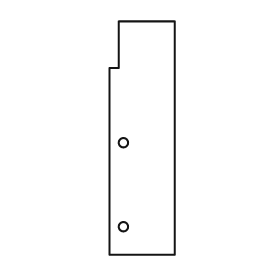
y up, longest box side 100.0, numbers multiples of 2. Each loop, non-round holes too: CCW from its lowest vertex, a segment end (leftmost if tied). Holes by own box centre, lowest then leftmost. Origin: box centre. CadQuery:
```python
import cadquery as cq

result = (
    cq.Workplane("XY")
    .moveTo(-14.0, -50.0)
    .lineTo(14.0, -50.0)
    .lineTo(14.0, 50.0)
    .lineTo(-10.0, 50.0)
    .lineTo(-10.0, 30.0)
    .lineTo(-14.0, 30.0)
    .close()
    .moveTo(-8.0, -38.0)
    .circle(2.0)
    .moveTo(-8.0, -2.0)
    .circle(2.0)
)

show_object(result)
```